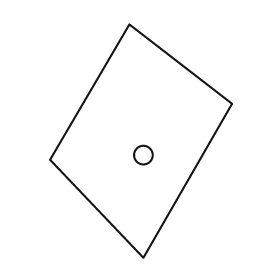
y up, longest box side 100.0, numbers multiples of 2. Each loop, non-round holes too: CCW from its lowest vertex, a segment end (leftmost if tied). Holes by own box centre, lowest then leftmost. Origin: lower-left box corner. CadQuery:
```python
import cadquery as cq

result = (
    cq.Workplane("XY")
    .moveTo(40.0, 0.0)
    .lineTo(78.0, 66.0)
    .lineTo(34.0, 100.0)
    .lineTo(0.0, 42.0)
    .close()
    .moveTo(40.0, 44.0)
    .circle(4.0)
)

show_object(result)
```